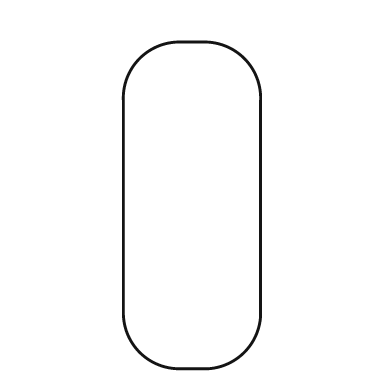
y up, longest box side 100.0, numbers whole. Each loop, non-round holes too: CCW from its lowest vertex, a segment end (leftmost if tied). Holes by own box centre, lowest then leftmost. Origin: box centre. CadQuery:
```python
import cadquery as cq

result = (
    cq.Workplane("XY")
    .moveTo(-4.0, -50.0)
    .lineTo(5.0, -50.0)
    .threePointArc((16.0, -45.0), (21.0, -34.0))
    .lineTo(21.0, 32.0)
    .threePointArc((16.0, 45.0), (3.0, 50.0))
    .lineTo(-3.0, 50.0)
    .threePointArc((-16.0, 45.0), (-21.0, 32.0))
    .lineTo(-21.0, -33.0)
    .threePointArc((-16.0, -45.0), (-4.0, -50.0))
    .close()
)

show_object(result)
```